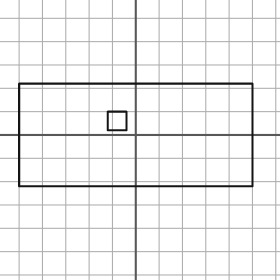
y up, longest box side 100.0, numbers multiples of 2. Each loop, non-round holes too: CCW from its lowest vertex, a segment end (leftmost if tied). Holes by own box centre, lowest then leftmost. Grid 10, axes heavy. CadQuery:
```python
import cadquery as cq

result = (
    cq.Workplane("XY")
    .moveTo(-50.0, -22.0)
    .lineTo(50.0, -22.0)
    .lineTo(50.0, 22.0)
    .lineTo(-50.0, 22.0)
    .close()
    .moveTo(-12.0, 2.0)
    .lineTo(-4.0, 2.0)
    .lineTo(-4.0, 10.0)
    .lineTo(-12.0, 10.0)
    .close()
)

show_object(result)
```